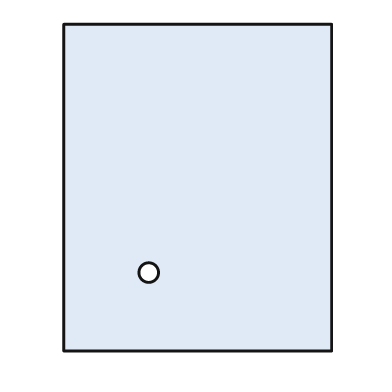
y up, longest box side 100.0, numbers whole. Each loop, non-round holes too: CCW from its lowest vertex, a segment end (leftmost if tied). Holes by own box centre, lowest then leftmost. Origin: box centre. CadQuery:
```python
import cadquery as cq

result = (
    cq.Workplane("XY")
    .moveTo(-41.0, -50.0)
    .lineTo(41.0, -50.0)
    .lineTo(41.0, 50.0)
    .lineTo(-41.0, 50.0)
    .close()
    .moveTo(-15.0, -26.0)
    .circle(3.0)
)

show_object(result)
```